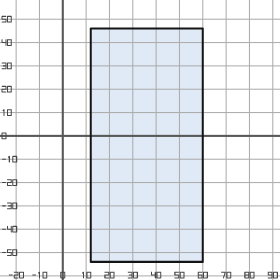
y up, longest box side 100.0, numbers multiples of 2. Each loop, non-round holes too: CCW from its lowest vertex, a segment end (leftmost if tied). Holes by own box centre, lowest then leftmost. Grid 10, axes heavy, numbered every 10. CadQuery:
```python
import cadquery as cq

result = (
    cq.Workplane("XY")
    .moveTo(12.0, -54.0)
    .lineTo(60.0, -54.0)
    .lineTo(60.0, 46.0)
    .lineTo(12.0, 46.0)
    .close()
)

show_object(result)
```